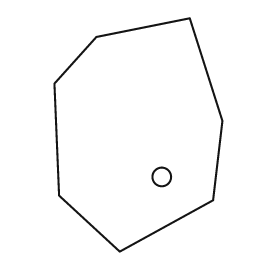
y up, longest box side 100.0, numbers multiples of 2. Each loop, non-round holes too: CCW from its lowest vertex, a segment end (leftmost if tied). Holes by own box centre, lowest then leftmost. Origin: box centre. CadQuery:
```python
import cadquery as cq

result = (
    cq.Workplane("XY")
    .moveTo(-8.0, -50.0)
    .lineTo(32.0, -28.0)
    .lineTo(36.0, 6.0)
    .lineTo(22.0, 50.0)
    .lineTo(-18.0, 42.0)
    .lineTo(-36.0, 22.0)
    .lineTo(-34.0, -26.0)
    .close()
    .moveTo(10.0, -18.0)
    .circle(4.0)
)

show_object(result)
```